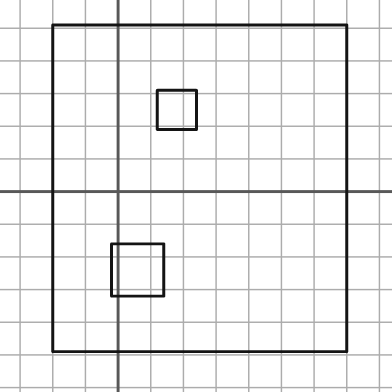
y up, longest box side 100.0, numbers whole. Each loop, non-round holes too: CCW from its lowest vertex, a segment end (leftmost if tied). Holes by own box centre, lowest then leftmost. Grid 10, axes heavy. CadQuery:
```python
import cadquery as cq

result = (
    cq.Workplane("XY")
    .moveTo(-20.0, -49.0)
    .lineTo(70.0, -49.0)
    .lineTo(70.0, 51.0)
    .lineTo(-20.0, 51.0)
    .close()
    .moveTo(-2.0, -32.0)
    .lineTo(14.0, -32.0)
    .lineTo(14.0, -16.0)
    .lineTo(-2.0, -16.0)
    .close()
    .moveTo(12.0, 19.0)
    .lineTo(24.0, 19.0)
    .lineTo(24.0, 31.0)
    .lineTo(12.0, 31.0)
    .close()
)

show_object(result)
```